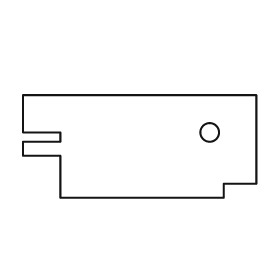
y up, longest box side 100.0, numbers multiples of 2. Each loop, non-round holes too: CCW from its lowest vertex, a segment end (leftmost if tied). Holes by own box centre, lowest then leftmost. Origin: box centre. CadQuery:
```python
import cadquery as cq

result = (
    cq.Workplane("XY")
    .moveTo(-34.0, -22.0)
    .lineTo(36.0, -22.0)
    .lineTo(36.0, -16.0)
    .lineTo(50.0, -16.0)
    .lineTo(50.0, 22.0)
    .lineTo(-50.0, 22.0)
    .lineTo(-50.0, 6.0)
    .lineTo(-34.0, 6.0)
    .lineTo(-34.0, 2.0)
    .lineTo(-50.0, 2.0)
    .lineTo(-50.0, -4.0)
    .lineTo(-34.0, -4.0)
    .close()
    .moveTo(30.0, 6.0)
    .circle(4.0)
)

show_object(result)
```